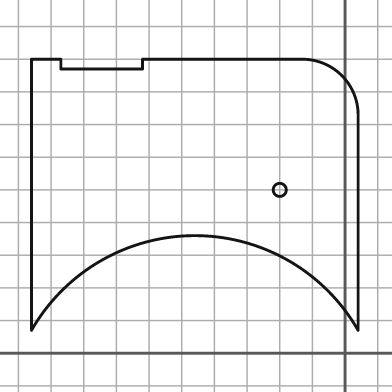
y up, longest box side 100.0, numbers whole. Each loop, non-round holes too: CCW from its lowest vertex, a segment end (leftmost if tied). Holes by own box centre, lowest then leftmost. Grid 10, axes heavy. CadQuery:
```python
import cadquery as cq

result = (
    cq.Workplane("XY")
    .moveTo(-96.0, 7.0)
    .threePointArc((-46.0, 36.0), (4.0, 7.0))
    .lineTo(4.0, 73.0)
    .threePointArc((-1.0, 85.0), (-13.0, 90.0))
    .lineTo(-62.0, 90.0)
    .lineTo(-62.0, 87.0)
    .lineTo(-87.0, 87.0)
    .lineTo(-87.0, 90.0)
    .lineTo(-96.0, 90.0)
    .close()
    .moveTo(-20.0, 50.0)
    .circle(2.0)
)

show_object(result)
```